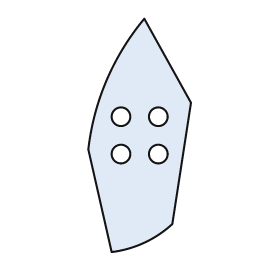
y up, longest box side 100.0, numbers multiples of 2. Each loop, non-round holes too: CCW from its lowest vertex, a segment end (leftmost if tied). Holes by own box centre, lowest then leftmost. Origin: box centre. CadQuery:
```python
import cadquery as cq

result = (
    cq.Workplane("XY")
    .moveTo(-12.0, -50.0)
    .threePointArc((2.0, -46.0), (14.0, -38.0))
    .lineTo(22.0, 14.0)
    .lineTo(2.0, 50.0)
    .threePointArc((-14.0, 24.0), (-22.0, -6.0))
    .close()
    .moveTo(-8.0, -8.0)
    .circle(4.0)
    .moveTo(8.0, -8.0)
    .circle(4.0)
    .moveTo(-8.0, 8.0)
    .circle(4.0)
    .moveTo(8.0, 8.0)
    .circle(4.0)
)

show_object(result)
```